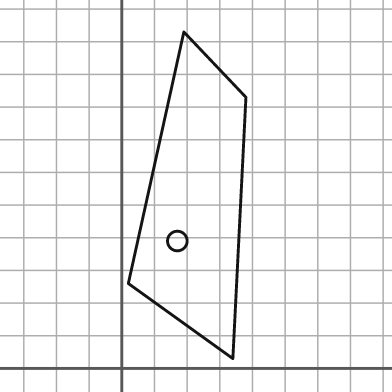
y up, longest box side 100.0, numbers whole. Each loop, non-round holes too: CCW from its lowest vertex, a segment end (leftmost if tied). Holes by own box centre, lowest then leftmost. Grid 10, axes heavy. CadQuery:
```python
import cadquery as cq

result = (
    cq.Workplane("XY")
    .moveTo(34.0, 3.0)
    .lineTo(38.0, 83.0)
    .lineTo(19.0, 103.0)
    .lineTo(2.0, 26.0)
    .close()
    .moveTo(17.0, 39.0)
    .circle(3.0)
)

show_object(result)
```